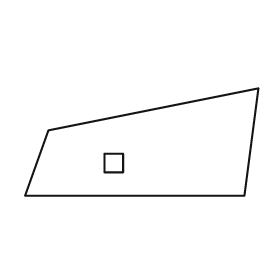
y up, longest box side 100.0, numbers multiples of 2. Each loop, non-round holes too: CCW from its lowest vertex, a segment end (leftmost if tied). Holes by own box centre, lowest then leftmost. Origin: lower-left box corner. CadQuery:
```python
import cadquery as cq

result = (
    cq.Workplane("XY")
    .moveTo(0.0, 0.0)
    .lineTo(94.0, 0.0)
    .lineTo(100.0, 46.0)
    .lineTo(10.0, 28.0)
    .close()
    .moveTo(34.0, 10.0)
    .lineTo(42.0, 10.0)
    .lineTo(42.0, 18.0)
    .lineTo(34.0, 18.0)
    .close()
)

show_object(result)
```